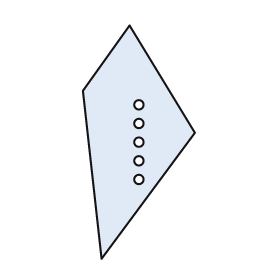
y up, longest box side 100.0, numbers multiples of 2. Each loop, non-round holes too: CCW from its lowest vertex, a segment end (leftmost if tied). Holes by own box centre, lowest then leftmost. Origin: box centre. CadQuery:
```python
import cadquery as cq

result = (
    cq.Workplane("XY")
    .moveTo(-16.0, -50.0)
    .lineTo(24.0, 4.0)
    .lineTo(-4.0, 50.0)
    .lineTo(-24.0, 22.0)
    .close()
    .moveTo(0.0, -16.0)
    .circle(2.0)
    .moveTo(0.0, -8.0)
    .circle(2.0)
    .moveTo(0.0, 0.0)
    .circle(2.0)
    .moveTo(0.0, 8.0)
    .circle(2.0)
    .moveTo(0.0, 16.0)
    .circle(2.0)
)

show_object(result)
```